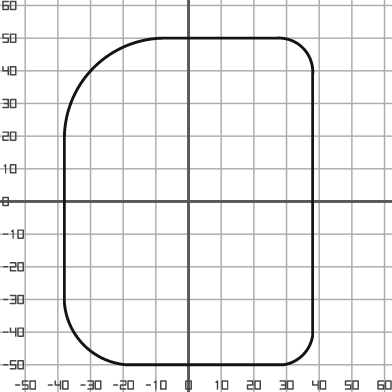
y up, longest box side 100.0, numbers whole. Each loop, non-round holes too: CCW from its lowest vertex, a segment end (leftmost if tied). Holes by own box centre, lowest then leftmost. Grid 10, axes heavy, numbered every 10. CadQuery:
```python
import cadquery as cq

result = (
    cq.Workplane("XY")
    .moveTo(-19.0, -50.0)
    .lineTo(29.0, -50.0)
    .threePointArc((35.0, -47.0), (38.0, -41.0))
    .lineTo(38.0, 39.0)
    .threePointArc((35.0, 47.0), (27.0, 50.0))
    .lineTo(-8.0, 50.0)
    .threePointArc((-29.0, 41.0), (-38.0, 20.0))
    .lineTo(-38.0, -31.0)
    .threePointArc((-32.0, -44.0), (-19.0, -50.0))
    .close()
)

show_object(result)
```